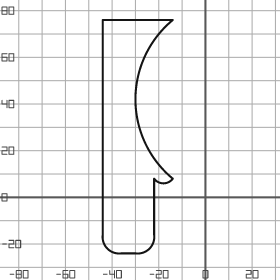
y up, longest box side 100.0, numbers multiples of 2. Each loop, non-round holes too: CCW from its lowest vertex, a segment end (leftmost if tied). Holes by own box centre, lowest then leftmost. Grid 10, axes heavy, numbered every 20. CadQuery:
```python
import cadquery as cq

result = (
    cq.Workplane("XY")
    .moveTo(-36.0, -24.0)
    .lineTo(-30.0, -24.0)
    .threePointArc((-24.0, -22.0), (-22.0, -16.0))
    .lineTo(-22.0, 8.0)
    .threePointArc((-18.0, 6.0), (-14.0, 8.0))
    .threePointArc((-30.0, 42.0), (-14.0, 76.0))
    .lineTo(-44.0, 76.0)
    .lineTo(-44.0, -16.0)
    .threePointArc((-42.0, -22.0), (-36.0, -24.0))
    .close()
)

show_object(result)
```